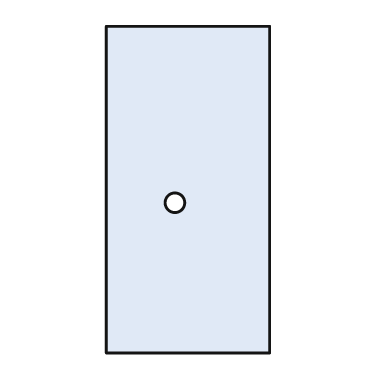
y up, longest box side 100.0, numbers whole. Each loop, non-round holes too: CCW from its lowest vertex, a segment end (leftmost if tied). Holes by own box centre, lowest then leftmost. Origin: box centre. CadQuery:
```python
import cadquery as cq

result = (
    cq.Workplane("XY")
    .moveTo(-25.0, -50.0)
    .lineTo(25.0, -50.0)
    .lineTo(25.0, 50.0)
    .lineTo(-25.0, 50.0)
    .close()
    .moveTo(-4.0, -4.0)
    .circle(3.0)
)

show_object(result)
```